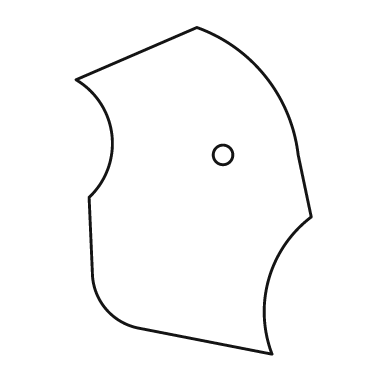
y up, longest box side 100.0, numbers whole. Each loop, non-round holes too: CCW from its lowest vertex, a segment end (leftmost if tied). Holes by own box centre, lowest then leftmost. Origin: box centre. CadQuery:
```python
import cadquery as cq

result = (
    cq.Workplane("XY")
    .moveTo(24.0, -50.0)
    .threePointArc((23.0, -27.0), (36.0, -8.0))
    .lineTo(32.0, 11.0)
    .threePointArc((22.0, 35.0), (1.0, 50.0))
    .lineTo(-36.0, 34.0)
    .threePointArc((-25.0, 17.0), (-32.0, -2.0))
    .lineTo(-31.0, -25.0)
    .threePointArc((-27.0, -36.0), (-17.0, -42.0))
    .close()
    .moveTo(9.0, 11.0)
    .circle(3.0)
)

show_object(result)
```